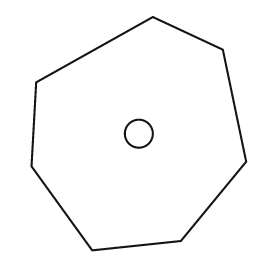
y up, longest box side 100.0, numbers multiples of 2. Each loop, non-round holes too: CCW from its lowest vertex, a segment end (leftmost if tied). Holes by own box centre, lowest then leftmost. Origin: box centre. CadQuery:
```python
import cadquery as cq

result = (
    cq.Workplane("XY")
    .moveTo(-20.0, -50.0)
    .lineTo(18.0, -46.0)
    .lineTo(46.0, -12.0)
    .lineTo(36.0, 36.0)
    .lineTo(6.0, 50.0)
    .lineTo(-44.0, 22.0)
    .lineTo(-46.0, -14.0)
    .close()
    .moveTo(0.0, 0.0)
    .circle(6.0)
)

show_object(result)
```